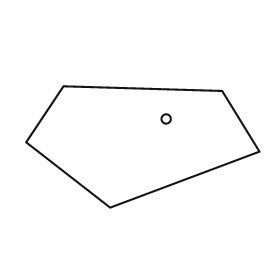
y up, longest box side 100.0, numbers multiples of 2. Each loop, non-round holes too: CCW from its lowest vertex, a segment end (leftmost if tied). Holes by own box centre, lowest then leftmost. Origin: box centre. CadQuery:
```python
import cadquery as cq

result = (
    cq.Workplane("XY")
    .moveTo(-14.0, -26.0)
    .lineTo(50.0, -2.0)
    .lineTo(34.0, 24.0)
    .lineTo(-34.0, 26.0)
    .lineTo(-50.0, 2.0)
    .close()
    .moveTo(10.0, 12.0)
    .circle(2.0)
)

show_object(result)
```